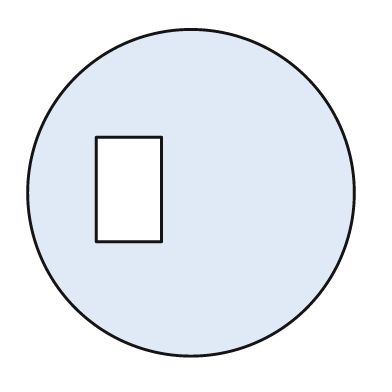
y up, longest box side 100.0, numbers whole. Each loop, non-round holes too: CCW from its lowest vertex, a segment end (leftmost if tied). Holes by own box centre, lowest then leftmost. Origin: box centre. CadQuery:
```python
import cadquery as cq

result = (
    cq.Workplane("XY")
    .moveTo(0.0, 0.0)
    .circle(50.0)
    .moveTo(-29.0, -15.0)
    .lineTo(-9.0, -15.0)
    .lineTo(-9.0, 17.0)
    .lineTo(-29.0, 17.0)
    .close()
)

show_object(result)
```